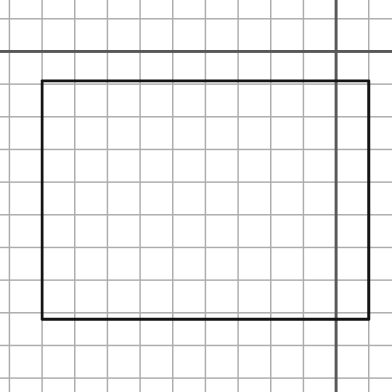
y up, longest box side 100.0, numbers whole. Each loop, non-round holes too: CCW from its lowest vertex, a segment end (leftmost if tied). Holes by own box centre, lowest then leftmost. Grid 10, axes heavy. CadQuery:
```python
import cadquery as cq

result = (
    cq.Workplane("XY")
    .moveTo(-90.0, -82.0)
    .lineTo(10.0, -82.0)
    .lineTo(10.0, -9.0)
    .lineTo(-90.0, -9.0)
    .close()
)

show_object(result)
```